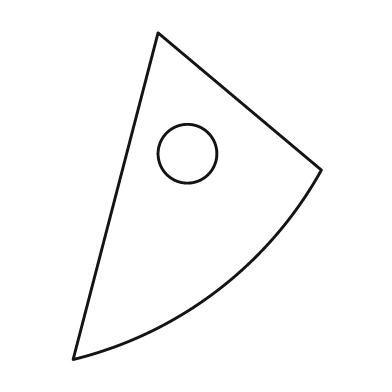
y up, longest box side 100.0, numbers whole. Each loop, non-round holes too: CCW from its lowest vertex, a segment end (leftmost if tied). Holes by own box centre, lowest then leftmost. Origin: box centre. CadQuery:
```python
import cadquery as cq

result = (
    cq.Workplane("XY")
    .moveTo(-38.0, -50.0)
    .threePointArc((6.0, -29.0), (38.0, 8.0))
    .lineTo(-12.0, 50.0)
    .close()
    .moveTo(-3.0, 13.0)
    .circle(9.0)
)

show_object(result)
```